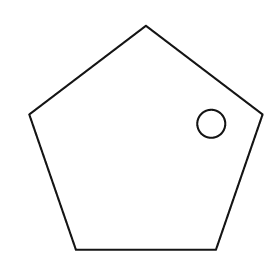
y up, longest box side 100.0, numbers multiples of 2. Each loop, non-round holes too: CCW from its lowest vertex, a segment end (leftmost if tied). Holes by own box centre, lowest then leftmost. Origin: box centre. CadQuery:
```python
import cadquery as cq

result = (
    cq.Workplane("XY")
    .moveTo(-30.0, -48.0)
    .lineTo(30.0, -48.0)
    .lineTo(50.0, 10.0)
    .lineTo(0.0, 48.0)
    .lineTo(-50.0, 10.0)
    .close()
    .moveTo(28.0, 6.0)
    .circle(6.0)
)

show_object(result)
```